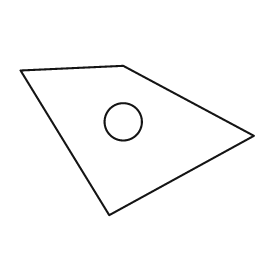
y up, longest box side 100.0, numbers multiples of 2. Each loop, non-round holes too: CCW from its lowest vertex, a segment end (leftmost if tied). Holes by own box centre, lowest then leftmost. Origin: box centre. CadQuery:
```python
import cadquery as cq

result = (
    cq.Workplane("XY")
    .moveTo(-12.0, -32.0)
    .lineTo(50.0, 2.0)
    .lineTo(-6.0, 32.0)
    .lineTo(-50.0, 30.0)
    .close()
    .moveTo(-6.0, 8.0)
    .circle(8.0)
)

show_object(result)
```